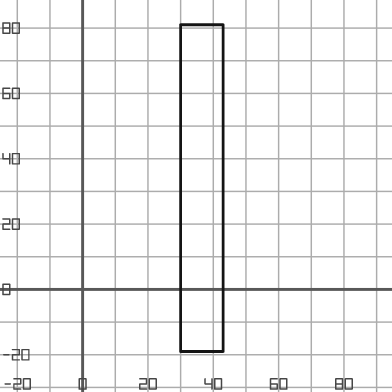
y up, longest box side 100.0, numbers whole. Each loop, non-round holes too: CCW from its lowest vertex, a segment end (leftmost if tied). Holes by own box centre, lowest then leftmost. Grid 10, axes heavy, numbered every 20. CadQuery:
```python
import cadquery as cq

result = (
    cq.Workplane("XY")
    .moveTo(30.0, -19.0)
    .lineTo(43.0, -19.0)
    .lineTo(43.0, 81.0)
    .lineTo(30.0, 81.0)
    .close()
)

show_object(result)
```